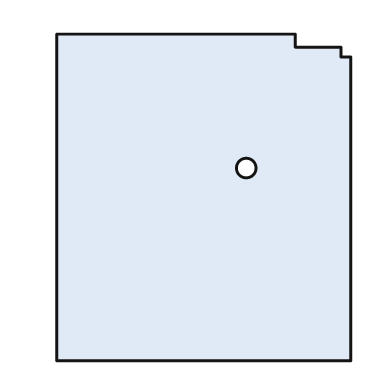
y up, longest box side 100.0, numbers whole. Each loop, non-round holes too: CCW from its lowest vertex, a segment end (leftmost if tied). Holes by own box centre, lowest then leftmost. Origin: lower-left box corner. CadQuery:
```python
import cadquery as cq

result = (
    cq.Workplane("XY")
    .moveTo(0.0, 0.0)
    .lineTo(90.0, 0.0)
    .lineTo(90.0, 93.0)
    .lineTo(87.0, 93.0)
    .lineTo(87.0, 96.0)
    .lineTo(73.0, 96.0)
    .lineTo(73.0, 100.0)
    .lineTo(0.0, 100.0)
    .close()
    .moveTo(58.0, 59.0)
    .circle(3.0)
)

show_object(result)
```